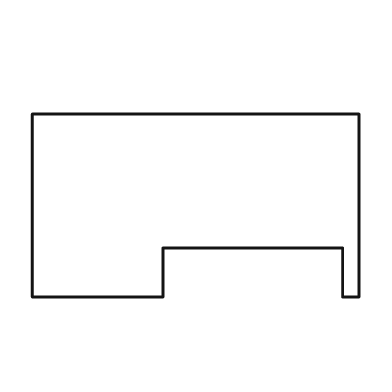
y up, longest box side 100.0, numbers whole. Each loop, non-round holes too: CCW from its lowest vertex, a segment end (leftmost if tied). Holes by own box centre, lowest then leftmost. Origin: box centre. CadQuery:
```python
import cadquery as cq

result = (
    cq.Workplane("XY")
    .moveTo(-50.0, -28.0)
    .lineTo(-10.0, -28.0)
    .lineTo(-10.0, -13.0)
    .lineTo(45.0, -13.0)
    .lineTo(45.0, -28.0)
    .lineTo(50.0, -28.0)
    .lineTo(50.0, 28.0)
    .lineTo(-50.0, 28.0)
    .close()
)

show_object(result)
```